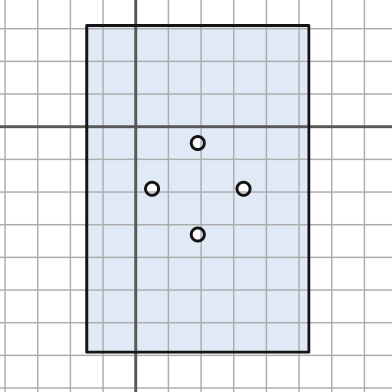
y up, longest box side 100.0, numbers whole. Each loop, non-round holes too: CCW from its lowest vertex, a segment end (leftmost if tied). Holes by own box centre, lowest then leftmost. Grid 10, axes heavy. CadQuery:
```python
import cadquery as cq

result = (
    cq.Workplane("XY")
    .moveTo(-15.0, -69.0)
    .lineTo(53.0, -69.0)
    .lineTo(53.0, 31.0)
    .lineTo(-15.0, 31.0)
    .close()
    .moveTo(19.0, -33.0)
    .circle(2.0)
    .moveTo(5.0, -19.0)
    .circle(2.0)
    .moveTo(33.0, -19.0)
    .circle(2.0)
    .moveTo(19.0, -5.0)
    .circle(2.0)
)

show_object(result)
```